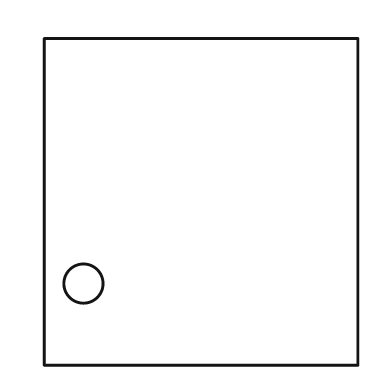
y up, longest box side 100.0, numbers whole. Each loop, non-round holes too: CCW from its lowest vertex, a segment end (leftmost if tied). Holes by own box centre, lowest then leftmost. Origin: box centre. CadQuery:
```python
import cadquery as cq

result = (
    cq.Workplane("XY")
    .moveTo(-48.0, -50.0)
    .lineTo(48.0, -50.0)
    .lineTo(48.0, 50.0)
    .lineTo(-48.0, 50.0)
    .close()
    .moveTo(-36.0, -25.0)
    .circle(6.0)
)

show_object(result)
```